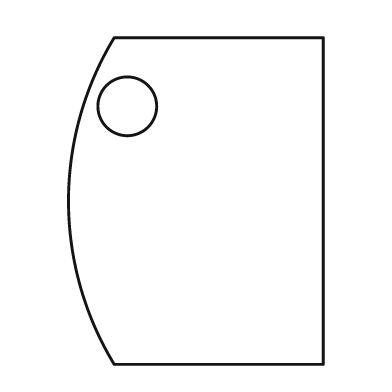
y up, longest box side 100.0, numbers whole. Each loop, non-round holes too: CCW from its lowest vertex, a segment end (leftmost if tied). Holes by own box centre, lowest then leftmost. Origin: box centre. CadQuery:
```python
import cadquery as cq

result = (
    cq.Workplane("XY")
    .moveTo(-25.0, -50.0)
    .lineTo(39.0, -50.0)
    .lineTo(39.0, 50.0)
    .lineTo(-25.0, 50.0)
    .threePointArc((-39.0, 0.0), (-25.0, -50.0))
    .close()
    .moveTo(-21.0, 29.0)
    .circle(9.0)
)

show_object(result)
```